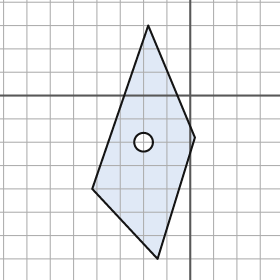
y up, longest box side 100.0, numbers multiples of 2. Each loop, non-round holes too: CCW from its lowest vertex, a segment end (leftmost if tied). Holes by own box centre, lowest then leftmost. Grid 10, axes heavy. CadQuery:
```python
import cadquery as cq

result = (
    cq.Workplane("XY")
    .moveTo(-14.0, -70.0)
    .lineTo(2.0, -18.0)
    .lineTo(-18.0, 30.0)
    .lineTo(-42.0, -40.0)
    .close()
    .moveTo(-20.0, -20.0)
    .circle(4.0)
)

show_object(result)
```